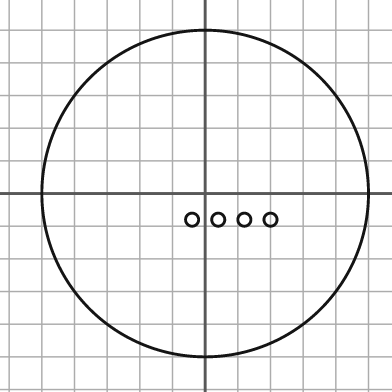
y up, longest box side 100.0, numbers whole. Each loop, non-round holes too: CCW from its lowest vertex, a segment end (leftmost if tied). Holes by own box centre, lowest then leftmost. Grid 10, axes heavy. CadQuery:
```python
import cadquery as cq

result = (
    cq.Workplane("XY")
    .moveTo(0.0, 0.0)
    .circle(50.0)
    .moveTo(-4.0, -8.0)
    .circle(2.0)
    .moveTo(4.0, -8.0)
    .circle(2.0)
    .moveTo(12.0, -8.0)
    .circle(2.0)
    .moveTo(20.0, -8.0)
    .circle(2.0)
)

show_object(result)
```